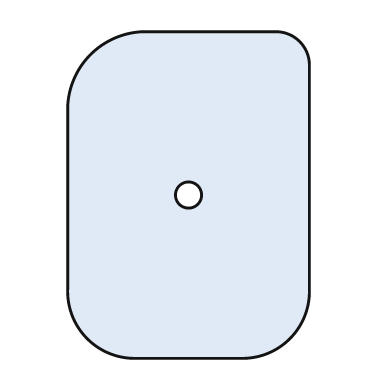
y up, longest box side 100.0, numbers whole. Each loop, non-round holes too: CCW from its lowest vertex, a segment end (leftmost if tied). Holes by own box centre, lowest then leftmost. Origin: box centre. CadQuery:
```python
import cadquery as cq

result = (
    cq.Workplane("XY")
    .moveTo(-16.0, -50.0)
    .lineTo(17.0, -50.0)
    .threePointArc((31.0, -44.0), (37.0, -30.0))
    .lineTo(37.0, 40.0)
    .threePointArc((34.0, 47.0), (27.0, 50.0))
    .lineTo(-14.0, 50.0)
    .threePointArc((-30.0, 43.0), (-37.0, 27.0))
    .lineTo(-37.0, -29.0)
    .threePointArc((-31.0, -44.0), (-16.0, -50.0))
    .close()
    .moveTo(0.0, 0.0)
    .circle(4.0)
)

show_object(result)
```